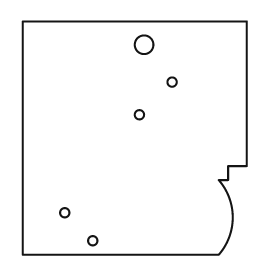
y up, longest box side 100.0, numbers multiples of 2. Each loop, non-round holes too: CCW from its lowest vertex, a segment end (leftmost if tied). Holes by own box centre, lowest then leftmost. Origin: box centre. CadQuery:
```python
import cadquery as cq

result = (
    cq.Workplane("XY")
    .moveTo(-48.0, -50.0)
    .lineTo(36.0, -50.0)
    .threePointArc((42.0, -34.0), (36.0, -18.0))
    .lineTo(40.0, -18.0)
    .lineTo(40.0, -12.0)
    .lineTo(48.0, -12.0)
    .lineTo(48.0, 50.0)
    .lineTo(-48.0, 50.0)
    .close()
    .moveTo(-18.0, -44.0)
    .circle(2.0)
    .moveTo(-30.0, -32.0)
    .circle(2.0)
    .moveTo(2.0, 10.0)
    .circle(2.0)
    .moveTo(16.0, 24.0)
    .circle(2.0)
    .moveTo(4.0, 40.0)
    .circle(4.0)
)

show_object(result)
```